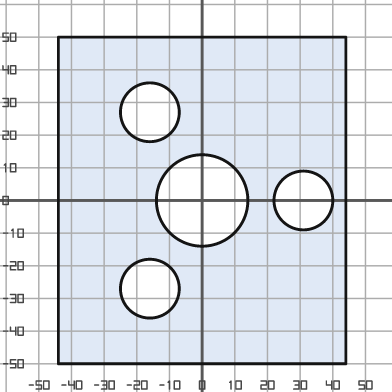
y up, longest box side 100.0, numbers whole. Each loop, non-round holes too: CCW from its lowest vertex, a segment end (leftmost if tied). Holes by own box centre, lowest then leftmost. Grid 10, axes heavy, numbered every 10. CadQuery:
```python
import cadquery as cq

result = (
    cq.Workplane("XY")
    .moveTo(-44.0, -50.0)
    .lineTo(44.0, -50.0)
    .lineTo(44.0, 50.0)
    .lineTo(-44.0, 50.0)
    .close()
    .moveTo(-16.0, -27.0)
    .circle(9.0)
    .moveTo(0.0, 0.0)
    .circle(14.0)
    .moveTo(31.0, 0.0)
    .circle(9.0)
    .moveTo(-16.0, 27.0)
    .circle(9.0)
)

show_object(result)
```